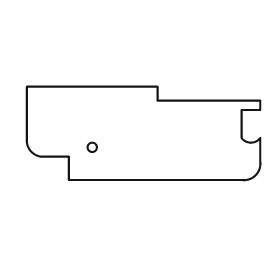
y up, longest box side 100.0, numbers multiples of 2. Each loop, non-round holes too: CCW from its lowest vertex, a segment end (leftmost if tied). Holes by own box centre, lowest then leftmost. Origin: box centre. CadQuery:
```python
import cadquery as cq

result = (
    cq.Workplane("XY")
    .moveTo(-32.0, -20.0)
    .lineTo(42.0, -20.0)
    .threePointArc((48.0, -18.0), (50.0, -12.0))
    .lineTo(50.0, -2.0)
    .threePointArc((46.0, -4.0), (42.0, -2.0))
    .lineTo(42.0, 10.0)
    .lineTo(50.0, 10.0)
    .lineTo(50.0, 14.0)
    .lineTo(6.0, 14.0)
    .lineTo(6.0, 20.0)
    .lineTo(-50.0, 20.0)
    .lineTo(-50.0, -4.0)
    .threePointArc((-48.0, -8.0), (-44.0, -10.0))
    .lineTo(-32.0, -10.0)
    .close()
    .moveTo(-22.0, -6.0)
    .circle(2.0)
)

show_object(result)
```